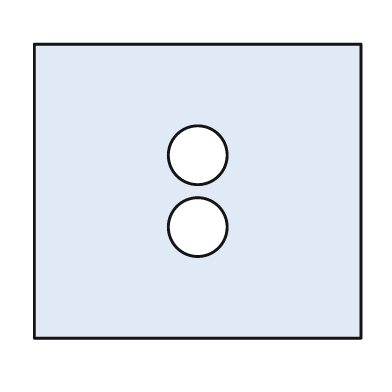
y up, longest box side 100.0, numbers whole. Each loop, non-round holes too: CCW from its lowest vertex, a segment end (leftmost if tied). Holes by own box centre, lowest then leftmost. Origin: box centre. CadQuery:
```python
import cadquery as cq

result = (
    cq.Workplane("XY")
    .moveTo(-50.0, -45.0)
    .lineTo(50.0, -45.0)
    .lineTo(50.0, 45.0)
    .lineTo(-50.0, 45.0)
    .close()
    .moveTo(0.0, -11.0)
    .circle(9.0)
    .moveTo(0.0, 11.0)
    .circle(9.0)
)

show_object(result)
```